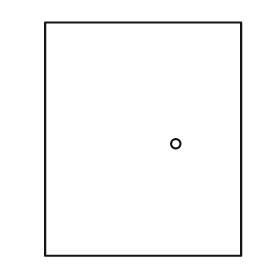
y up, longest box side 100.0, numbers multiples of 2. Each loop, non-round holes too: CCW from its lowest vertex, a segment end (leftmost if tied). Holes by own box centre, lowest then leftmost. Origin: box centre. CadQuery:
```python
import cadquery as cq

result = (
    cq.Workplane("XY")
    .moveTo(-42.0, -50.0)
    .lineTo(42.0, -50.0)
    .lineTo(42.0, 50.0)
    .lineTo(-42.0, 50.0)
    .close()
    .moveTo(14.0, -2.0)
    .circle(2.0)
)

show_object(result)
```